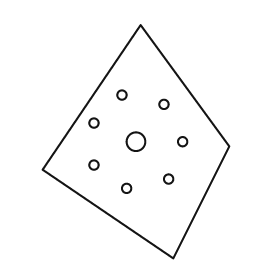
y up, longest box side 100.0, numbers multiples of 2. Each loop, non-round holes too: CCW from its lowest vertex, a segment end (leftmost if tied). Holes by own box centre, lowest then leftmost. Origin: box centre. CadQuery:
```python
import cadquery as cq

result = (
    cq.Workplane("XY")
    .moveTo(16.0, -50.0)
    .lineTo(40.0, -2.0)
    .lineTo(2.0, 50.0)
    .lineTo(-40.0, -12.0)
    .close()
    .moveTo(-4.0, -20.0)
    .circle(2.0)
    .moveTo(14.0, -16.0)
    .circle(2.0)
    .moveTo(-18.0, -10.0)
    .circle(2.0)
    .moveTo(0.0, 0.0)
    .circle(4.0)
    .moveTo(20.0, 0.0)
    .circle(2.0)
    .moveTo(-18.0, 8.0)
    .circle(2.0)
    .moveTo(12.0, 16.0)
    .circle(2.0)
    .moveTo(-6.0, 20.0)
    .circle(2.0)
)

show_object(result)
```